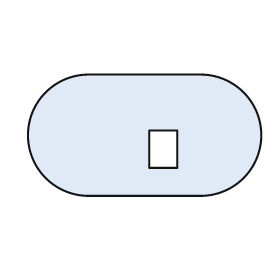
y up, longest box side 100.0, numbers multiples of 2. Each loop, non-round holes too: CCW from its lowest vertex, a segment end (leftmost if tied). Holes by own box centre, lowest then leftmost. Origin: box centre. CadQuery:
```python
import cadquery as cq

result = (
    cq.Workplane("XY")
    .moveTo(-24.0, -26.0)
    .lineTo(24.0, -26.0)
    .threePointArc((50.0, 0.0), (24.0, 26.0))
    .lineTo(-24.0, 26.0)
    .threePointArc((-50.0, 0.0), (-24.0, -26.0))
    .close()
    .moveTo(2.0, -14.0)
    .lineTo(14.0, -14.0)
    .lineTo(14.0, 2.0)
    .lineTo(2.0, 2.0)
    .close()
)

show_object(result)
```